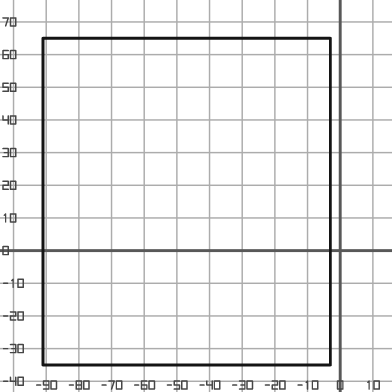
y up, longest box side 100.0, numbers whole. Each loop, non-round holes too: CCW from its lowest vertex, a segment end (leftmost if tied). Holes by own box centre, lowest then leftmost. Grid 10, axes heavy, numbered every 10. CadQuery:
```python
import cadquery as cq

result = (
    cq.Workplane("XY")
    .moveTo(-91.0, -35.0)
    .lineTo(-3.0, -35.0)
    .lineTo(-3.0, 65.0)
    .lineTo(-91.0, 65.0)
    .close()
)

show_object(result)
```